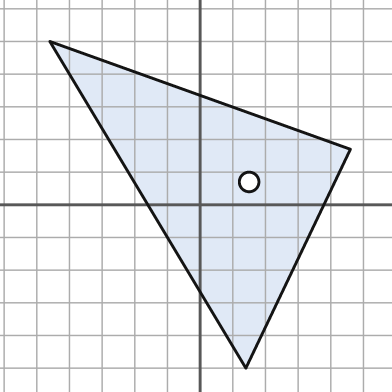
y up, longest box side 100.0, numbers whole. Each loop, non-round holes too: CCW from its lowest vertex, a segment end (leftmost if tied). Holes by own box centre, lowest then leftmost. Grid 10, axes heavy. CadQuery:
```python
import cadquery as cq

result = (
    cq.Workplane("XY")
    .moveTo(14.0, -50.0)
    .lineTo(46.0, 17.0)
    .lineTo(-46.0, 50.0)
    .close()
    .moveTo(15.0, 7.0)
    .circle(3.0)
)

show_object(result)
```